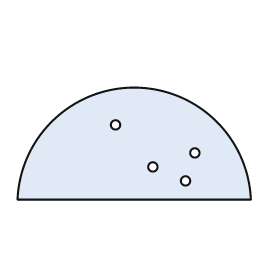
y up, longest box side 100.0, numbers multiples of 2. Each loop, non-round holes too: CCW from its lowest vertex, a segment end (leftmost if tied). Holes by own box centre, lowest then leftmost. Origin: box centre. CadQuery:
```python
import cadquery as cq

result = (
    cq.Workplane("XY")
    .moveTo(-50.0, -24.0)
    .lineTo(50.0, -24.0)
    .threePointArc((0.0, 24.0), (-50.0, -24.0))
    .close()
    .moveTo(22.0, -16.0)
    .circle(2.0)
    .moveTo(8.0, -10.0)
    .circle(2.0)
    .moveTo(26.0, -4.0)
    .circle(2.0)
    .moveTo(-8.0, 8.0)
    .circle(2.0)
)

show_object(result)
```